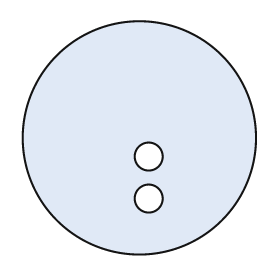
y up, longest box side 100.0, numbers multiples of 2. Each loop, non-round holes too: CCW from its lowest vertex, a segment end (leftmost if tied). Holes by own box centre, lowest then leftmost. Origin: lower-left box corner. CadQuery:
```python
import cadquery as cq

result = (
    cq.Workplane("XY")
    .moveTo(50.0, 50.0)
    .circle(50.0)
    .moveTo(54.0, 24.0)
    .circle(6.0)
    .moveTo(54.0, 42.0)
    .circle(6.0)
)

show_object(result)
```